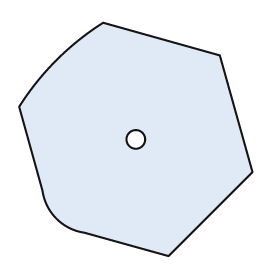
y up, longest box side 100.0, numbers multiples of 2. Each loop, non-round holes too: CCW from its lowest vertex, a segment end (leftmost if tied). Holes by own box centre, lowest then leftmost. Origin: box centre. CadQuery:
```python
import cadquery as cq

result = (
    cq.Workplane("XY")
    .moveTo(14.0, -50.0)
    .lineTo(50.0, -14.0)
    .lineTo(36.0, 36.0)
    .lineTo(-14.0, 50.0)
    .threePointArc((-34.0, 34.0), (-50.0, 14.0))
    .lineTo(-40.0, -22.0)
    .threePointArc((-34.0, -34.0), (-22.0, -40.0))
    .close()
    .moveTo(0.0, 0.0)
    .circle(4.0)
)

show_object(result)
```